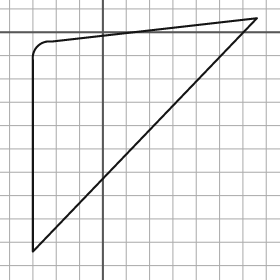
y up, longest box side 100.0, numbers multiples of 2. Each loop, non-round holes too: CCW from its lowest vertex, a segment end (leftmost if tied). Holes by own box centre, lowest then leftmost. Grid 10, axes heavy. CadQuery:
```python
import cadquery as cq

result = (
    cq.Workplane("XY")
    .moveTo(-30.0, -94.0)
    .lineTo(66.0, 6.0)
    .lineTo(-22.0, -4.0)
    .threePointArc((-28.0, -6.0), (-30.0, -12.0))
    .close()
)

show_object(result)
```